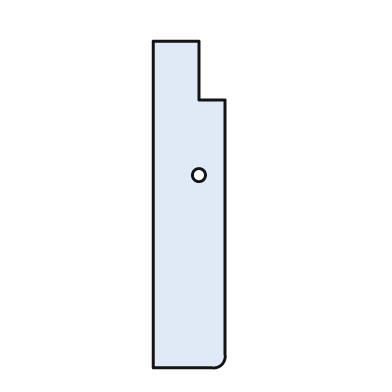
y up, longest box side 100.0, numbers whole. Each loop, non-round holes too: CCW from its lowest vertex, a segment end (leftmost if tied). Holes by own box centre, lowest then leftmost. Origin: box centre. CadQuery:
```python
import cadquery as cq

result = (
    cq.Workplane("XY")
    .moveTo(-11.0, -50.0)
    .lineTo(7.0, -50.0)
    .threePointArc((10.0, -49.0), (11.0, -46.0))
    .lineTo(11.0, 32.0)
    .lineTo(3.0, 32.0)
    .lineTo(3.0, 50.0)
    .lineTo(-11.0, 50.0)
    .close()
    .moveTo(3.0, 9.0)
    .circle(2.0)
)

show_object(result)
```